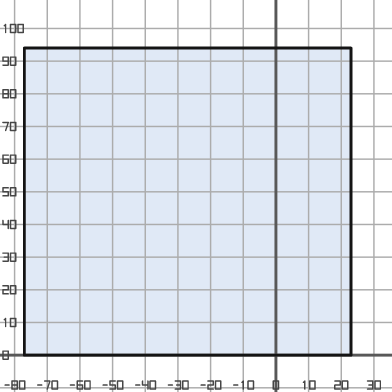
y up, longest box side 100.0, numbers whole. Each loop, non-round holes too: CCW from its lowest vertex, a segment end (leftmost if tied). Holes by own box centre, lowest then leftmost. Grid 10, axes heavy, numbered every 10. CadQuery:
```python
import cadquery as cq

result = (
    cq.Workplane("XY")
    .moveTo(-77.0, 0.0)
    .lineTo(23.0, 0.0)
    .lineTo(23.0, 94.0)
    .lineTo(-77.0, 94.0)
    .close()
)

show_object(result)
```